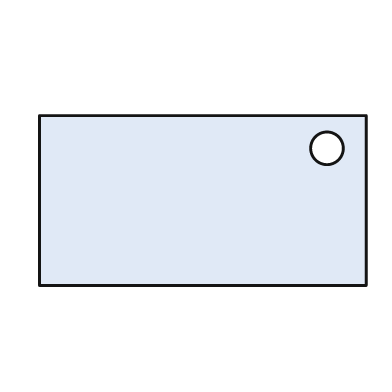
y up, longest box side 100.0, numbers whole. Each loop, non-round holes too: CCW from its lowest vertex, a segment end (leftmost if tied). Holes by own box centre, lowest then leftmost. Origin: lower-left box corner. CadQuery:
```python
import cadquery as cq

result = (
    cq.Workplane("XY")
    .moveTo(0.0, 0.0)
    .lineTo(100.0, 0.0)
    .lineTo(100.0, 52.0)
    .lineTo(0.0, 52.0)
    .close()
    .moveTo(88.0, 42.0)
    .circle(5.0)
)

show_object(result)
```